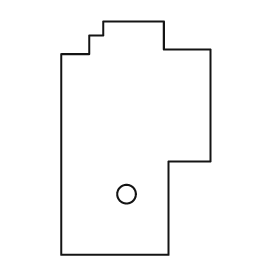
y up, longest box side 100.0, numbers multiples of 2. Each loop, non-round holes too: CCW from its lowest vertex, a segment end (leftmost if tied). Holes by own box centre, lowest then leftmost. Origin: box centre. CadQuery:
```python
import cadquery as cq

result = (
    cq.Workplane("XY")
    .moveTo(-32.0, -50.0)
    .lineTo(14.0, -50.0)
    .lineTo(14.0, -10.0)
    .lineTo(32.0, -10.0)
    .lineTo(32.0, 38.0)
    .lineTo(12.0, 38.0)
    .lineTo(12.0, 50.0)
    .lineTo(-14.0, 50.0)
    .lineTo(-14.0, 44.0)
    .lineTo(-20.0, 44.0)
    .lineTo(-20.0, 36.0)
    .lineTo(-32.0, 36.0)
    .close()
    .moveTo(-4.0, -24.0)
    .circle(4.0)
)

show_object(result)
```